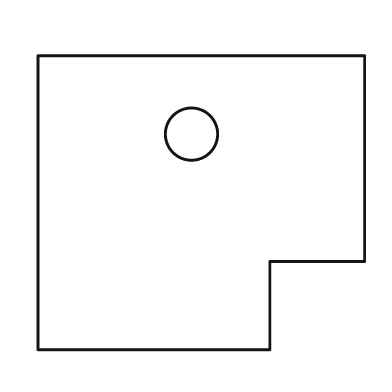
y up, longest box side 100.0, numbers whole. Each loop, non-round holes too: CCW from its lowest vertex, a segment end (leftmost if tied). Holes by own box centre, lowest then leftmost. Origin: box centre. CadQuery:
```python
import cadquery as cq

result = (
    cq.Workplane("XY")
    .moveTo(-50.0, -45.0)
    .lineTo(21.0, -45.0)
    .lineTo(21.0, -18.0)
    .lineTo(50.0, -18.0)
    .lineTo(50.0, 45.0)
    .lineTo(-50.0, 45.0)
    .close()
    .moveTo(-3.0, 21.0)
    .circle(8.0)
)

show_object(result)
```